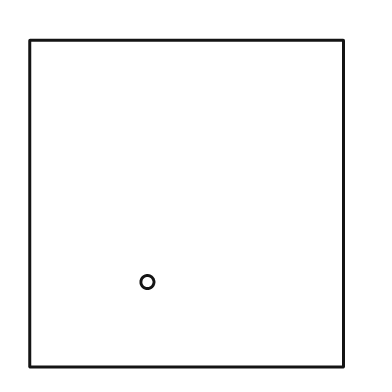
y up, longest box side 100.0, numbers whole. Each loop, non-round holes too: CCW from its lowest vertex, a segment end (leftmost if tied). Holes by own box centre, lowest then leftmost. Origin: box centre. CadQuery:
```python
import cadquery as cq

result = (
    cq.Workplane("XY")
    .moveTo(-48.0, -50.0)
    .lineTo(48.0, -50.0)
    .lineTo(48.0, 50.0)
    .lineTo(-48.0, 50.0)
    .close()
    .moveTo(-12.0, -24.0)
    .circle(2.0)
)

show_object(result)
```